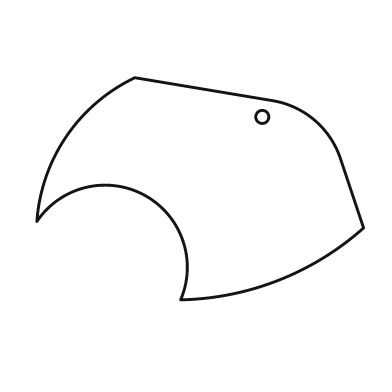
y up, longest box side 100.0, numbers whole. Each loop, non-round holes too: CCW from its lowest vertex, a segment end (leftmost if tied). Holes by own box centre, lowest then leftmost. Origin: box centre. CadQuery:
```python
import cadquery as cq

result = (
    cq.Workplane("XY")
    .moveTo(-6.0, -34.0)
    .threePointArc((24.0, -28.0), (50.0, -12.0))
    .lineTo(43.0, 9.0)
    .threePointArc((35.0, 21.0), (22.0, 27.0))
    .lineTo(-20.0, 34.0)
    .threePointArc((-41.0, 16.0), (-50.0, -10.0))
    .threePointArc((-17.0, -2.0), (-6.0, -34.0))
    .close()
    .moveTo(19.0, 22.0)
    .circle(2.0)
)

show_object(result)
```